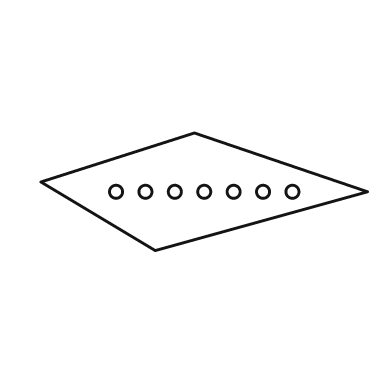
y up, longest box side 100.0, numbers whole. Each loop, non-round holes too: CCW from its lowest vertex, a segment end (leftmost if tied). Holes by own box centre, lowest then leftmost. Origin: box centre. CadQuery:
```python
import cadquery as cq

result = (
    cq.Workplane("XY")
    .moveTo(-15.0, -18.0)
    .lineTo(50.0, 0.0)
    .lineTo(-3.0, 18.0)
    .lineTo(-50.0, 3.0)
    .close()
    .moveTo(-27.0, 0.0)
    .circle(2.0)
    .moveTo(-18.0, 0.0)
    .circle(2.0)
    .moveTo(-9.0, 0.0)
    .circle(2.0)
    .moveTo(0.0, 0.0)
    .circle(2.0)
    .moveTo(9.0, 0.0)
    .circle(2.0)
    .moveTo(18.0, 0.0)
    .circle(2.0)
    .moveTo(27.0, 0.0)
    .circle(2.0)
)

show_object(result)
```